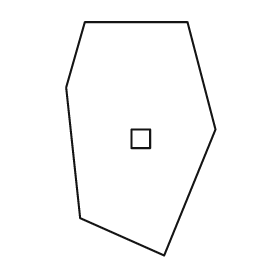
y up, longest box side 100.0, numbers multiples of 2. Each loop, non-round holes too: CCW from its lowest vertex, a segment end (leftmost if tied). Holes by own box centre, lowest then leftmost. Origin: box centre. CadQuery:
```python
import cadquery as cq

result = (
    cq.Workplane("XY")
    .moveTo(10.0, -50.0)
    .lineTo(32.0, 4.0)
    .lineTo(20.0, 50.0)
    .lineTo(-24.0, 50.0)
    .lineTo(-32.0, 22.0)
    .lineTo(-26.0, -34.0)
    .close()
    .moveTo(-4.0, -4.0)
    .lineTo(4.0, -4.0)
    .lineTo(4.0, 4.0)
    .lineTo(-4.0, 4.0)
    .close()
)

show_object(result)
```